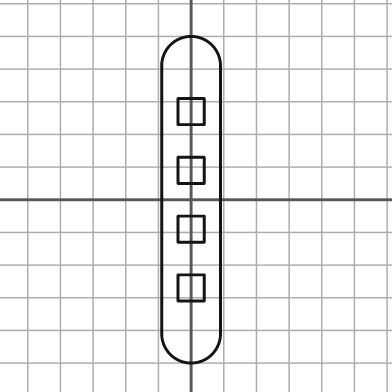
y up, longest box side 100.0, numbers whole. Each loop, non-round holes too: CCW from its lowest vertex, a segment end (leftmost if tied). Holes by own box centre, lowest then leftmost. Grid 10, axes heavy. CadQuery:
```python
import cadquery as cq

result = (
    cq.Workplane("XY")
    .moveTo(-9.0, -41.0)
    .threePointArc((0.0, -50.0), (9.0, -41.0))
    .lineTo(9.0, 41.0)
    .threePointArc((0.0, 50.0), (-9.0, 41.0))
    .close()
    .moveTo(-4.0, -31.0)
    .lineTo(4.0, -31.0)
    .lineTo(4.0, -23.0)
    .lineTo(-4.0, -23.0)
    .close()
    .moveTo(-4.0, -13.0)
    .lineTo(4.0, -13.0)
    .lineTo(4.0, -5.0)
    .lineTo(-4.0, -5.0)
    .close()
    .moveTo(-4.0, 5.0)
    .lineTo(4.0, 5.0)
    .lineTo(4.0, 13.0)
    .lineTo(-4.0, 13.0)
    .close()
    .moveTo(-4.0, 23.0)
    .lineTo(4.0, 23.0)
    .lineTo(4.0, 31.0)
    .lineTo(-4.0, 31.0)
    .close()
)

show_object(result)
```